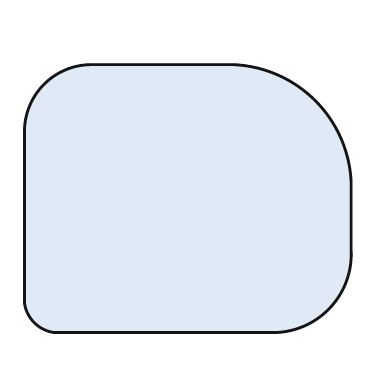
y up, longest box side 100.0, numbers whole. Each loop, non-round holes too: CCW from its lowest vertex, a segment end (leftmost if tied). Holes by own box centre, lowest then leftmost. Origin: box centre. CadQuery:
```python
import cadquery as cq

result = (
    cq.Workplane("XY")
    .moveTo(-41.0, -41.0)
    .lineTo(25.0, -41.0)
    .threePointArc((43.0, -34.0), (50.0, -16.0))
    .lineTo(50.0, 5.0)
    .threePointArc((39.0, 30.0), (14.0, 41.0))
    .lineTo(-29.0, 41.0)
    .threePointArc((-44.0, 35.0), (-50.0, 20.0))
    .lineTo(-50.0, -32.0)
    .threePointArc((-47.0, -38.0), (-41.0, -41.0))
    .close()
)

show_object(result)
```